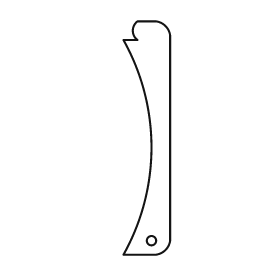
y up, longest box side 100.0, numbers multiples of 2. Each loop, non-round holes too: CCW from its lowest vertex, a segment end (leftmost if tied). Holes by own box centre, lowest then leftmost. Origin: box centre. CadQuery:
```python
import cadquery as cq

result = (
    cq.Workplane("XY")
    .moveTo(-10.0, -50.0)
    .lineTo(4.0, -50.0)
    .threePointArc((8.0, -48.0), (10.0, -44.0))
    .lineTo(10.0, 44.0)
    .threePointArc((8.0, 48.0), (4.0, 50.0))
    .lineTo(-4.0, 50.0)
    .threePointArc((-6.0, 46.0), (-4.0, 42.0))
    .lineTo(-10.0, 42.0)
    .threePointArc((2.0, -4.0), (-10.0, -50.0))
    .close()
    .moveTo(2.0, -44.0)
    .circle(2.0)
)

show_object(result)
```